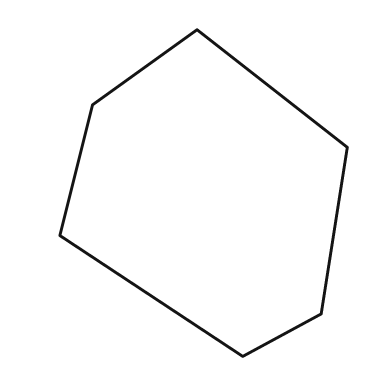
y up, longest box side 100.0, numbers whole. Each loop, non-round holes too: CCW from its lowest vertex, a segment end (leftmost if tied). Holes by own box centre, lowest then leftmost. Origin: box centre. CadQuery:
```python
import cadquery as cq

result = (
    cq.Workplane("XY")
    .moveTo(12.0, -50.0)
    .lineTo(36.0, -37.0)
    .lineTo(44.0, 14.0)
    .lineTo(-2.0, 50.0)
    .lineTo(-34.0, 27.0)
    .lineTo(-44.0, -13.0)
    .close()
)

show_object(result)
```